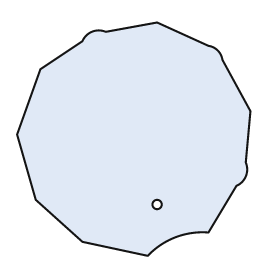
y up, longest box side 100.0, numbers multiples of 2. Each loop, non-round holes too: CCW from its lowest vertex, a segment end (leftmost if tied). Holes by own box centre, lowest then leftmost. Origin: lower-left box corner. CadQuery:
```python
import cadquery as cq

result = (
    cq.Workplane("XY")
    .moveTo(56.0, 0.0)
    .threePointArc((68.0, 8.0), (82.0, 10.0))
    .lineTo(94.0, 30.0)
    .threePointArc((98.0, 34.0), (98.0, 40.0))
    .lineTo(100.0, 62.0)
    .lineTo(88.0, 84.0)
    .threePointArc((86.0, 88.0), (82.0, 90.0))
    .lineTo(60.0, 100.0)
    .lineTo(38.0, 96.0)
    .threePointArc((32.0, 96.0), (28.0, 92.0))
    .lineTo(10.0, 80.0)
    .lineTo(0.0, 52.0)
    .lineTo(8.0, 24.0)
    .lineTo(28.0, 6.0)
    .close()
    .moveTo(60.0, 22.0)
    .circle(2.0)
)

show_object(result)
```